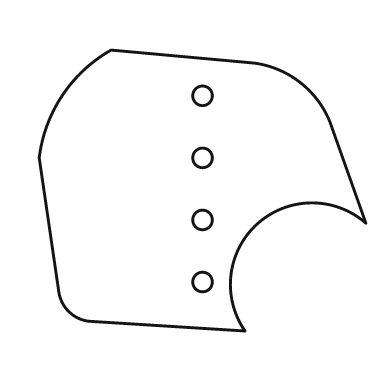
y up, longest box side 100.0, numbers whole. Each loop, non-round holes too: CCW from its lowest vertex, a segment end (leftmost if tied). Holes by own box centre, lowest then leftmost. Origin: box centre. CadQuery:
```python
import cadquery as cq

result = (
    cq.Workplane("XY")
    .moveTo(13.0, -43.0)
    .threePointArc((17.0, -10.0), (50.0, -10.0))
    .lineTo(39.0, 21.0)
    .threePointArc((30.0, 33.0), (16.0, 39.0))
    .lineTo(-28.0, 43.0)
    .threePointArc((-43.0, 29.0), (-50.0, 10.0))
    .lineTo(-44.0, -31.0)
    .threePointArc((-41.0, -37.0), (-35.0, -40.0))
    .close()
    .moveTo(0.0, -28.0)
    .circle(3.0)
    .moveTo(0.0, -9.0)
    .circle(3.0)
    .moveTo(0.0, 10.0)
    .circle(3.0)
    .moveTo(0.0, 29.0)
    .circle(3.0)
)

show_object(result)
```